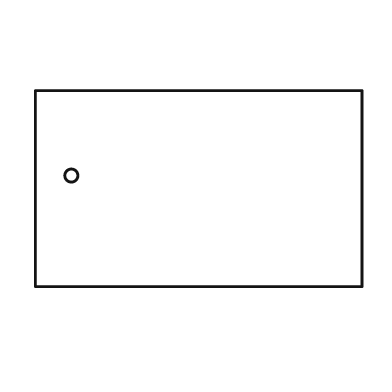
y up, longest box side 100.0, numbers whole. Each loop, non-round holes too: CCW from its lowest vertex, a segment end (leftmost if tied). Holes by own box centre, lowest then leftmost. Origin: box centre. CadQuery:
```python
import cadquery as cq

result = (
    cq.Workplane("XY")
    .moveTo(-50.0, -30.0)
    .lineTo(50.0, -30.0)
    .lineTo(50.0, 30.0)
    .lineTo(-50.0, 30.0)
    .close()
    .moveTo(-39.0, 4.0)
    .circle(2.0)
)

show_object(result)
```